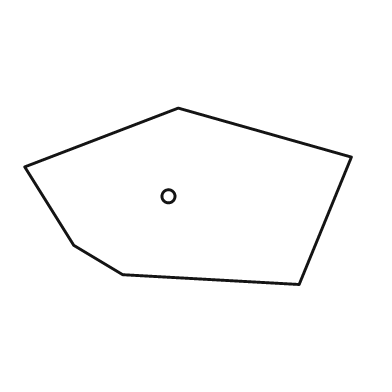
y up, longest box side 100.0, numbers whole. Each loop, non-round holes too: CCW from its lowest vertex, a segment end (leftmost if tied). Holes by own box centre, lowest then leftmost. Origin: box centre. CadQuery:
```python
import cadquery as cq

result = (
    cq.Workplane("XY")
    .moveTo(34.0, -27.0)
    .lineTo(50.0, 12.0)
    .lineTo(-3.0, 27.0)
    .lineTo(-50.0, 9.0)
    .lineTo(-35.0, -15.0)
    .lineTo(-20.0, -24.0)
    .close()
    .moveTo(-6.0, 0.0)
    .circle(2.0)
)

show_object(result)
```